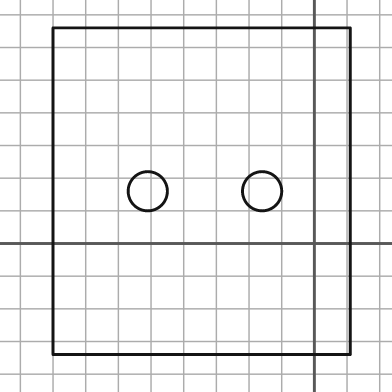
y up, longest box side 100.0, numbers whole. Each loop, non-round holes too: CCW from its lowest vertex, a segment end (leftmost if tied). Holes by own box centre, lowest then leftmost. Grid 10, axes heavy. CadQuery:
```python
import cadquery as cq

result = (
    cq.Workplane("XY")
    .moveTo(-80.0, -34.0)
    .lineTo(11.0, -34.0)
    .lineTo(11.0, 66.0)
    .lineTo(-80.0, 66.0)
    .close()
    .moveTo(-51.0, 16.0)
    .circle(6.0)
    .moveTo(-16.0, 16.0)
    .circle(6.0)
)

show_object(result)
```